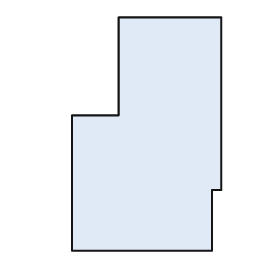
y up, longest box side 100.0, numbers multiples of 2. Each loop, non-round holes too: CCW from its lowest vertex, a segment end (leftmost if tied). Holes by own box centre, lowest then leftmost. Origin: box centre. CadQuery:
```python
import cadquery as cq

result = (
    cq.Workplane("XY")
    .moveTo(-32.0, -50.0)
    .lineTo(28.0, -50.0)
    .lineTo(28.0, -24.0)
    .lineTo(32.0, -24.0)
    .lineTo(32.0, 50.0)
    .lineTo(-12.0, 50.0)
    .lineTo(-12.0, 8.0)
    .lineTo(-32.0, 8.0)
    .close()
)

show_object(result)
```